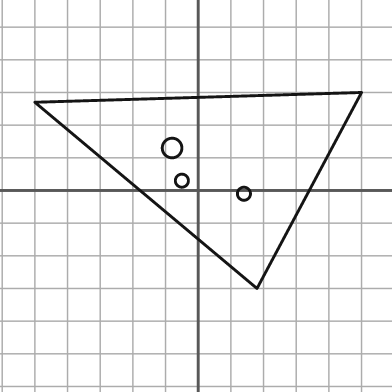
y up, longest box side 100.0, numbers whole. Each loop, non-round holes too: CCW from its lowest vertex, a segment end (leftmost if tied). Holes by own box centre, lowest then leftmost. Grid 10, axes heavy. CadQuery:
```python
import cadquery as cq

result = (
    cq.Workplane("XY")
    .moveTo(18.0, -30.0)
    .lineTo(50.0, 30.0)
    .lineTo(-50.0, 27.0)
    .close()
    .moveTo(14.0, -1.0)
    .circle(2.0)
    .moveTo(-5.0, 3.0)
    .circle(2.0)
    .moveTo(-8.0, 13.0)
    .circle(3.0)
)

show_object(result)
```